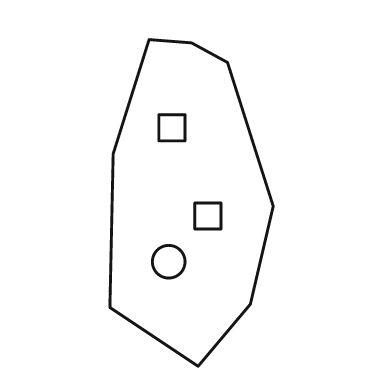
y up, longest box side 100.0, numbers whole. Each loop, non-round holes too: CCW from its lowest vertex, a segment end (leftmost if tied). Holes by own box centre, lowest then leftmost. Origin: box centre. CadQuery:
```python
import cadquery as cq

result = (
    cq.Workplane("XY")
    .moveTo(2.0, -50.0)
    .lineTo(18.0, -31.0)
    .lineTo(25.0, -1.0)
    .lineTo(11.0, 43.0)
    .lineTo(0.0, 49.0)
    .lineTo(-13.0, 50.0)
    .lineTo(-24.0, 15.0)
    .lineTo(-25.0, -32.0)
    .close()
    .moveTo(-7.0, -18.0)
    .circle(5.0)
    .moveTo(1.0, -8.0)
    .lineTo(9.0, -8.0)
    .lineTo(9.0, 0.0)
    .lineTo(1.0, 0.0)
    .close()
    .moveTo(-10.0, 19.0)
    .lineTo(-2.0, 19.0)
    .lineTo(-2.0, 27.0)
    .lineTo(-10.0, 27.0)
    .close()
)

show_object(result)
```